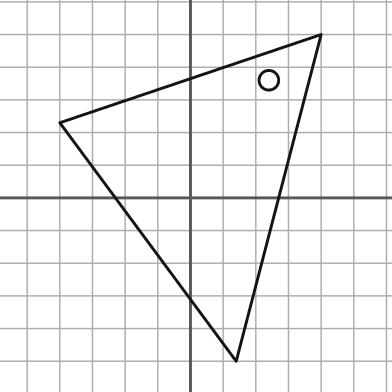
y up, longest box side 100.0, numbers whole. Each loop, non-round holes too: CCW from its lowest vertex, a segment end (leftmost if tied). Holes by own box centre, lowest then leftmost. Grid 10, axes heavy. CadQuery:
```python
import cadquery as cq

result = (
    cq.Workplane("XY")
    .moveTo(14.0, -50.0)
    .lineTo(40.0, 50.0)
    .lineTo(-40.0, 23.0)
    .close()
    .moveTo(24.0, 36.0)
    .circle(3.0)
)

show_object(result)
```